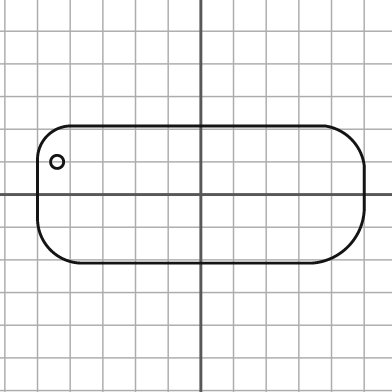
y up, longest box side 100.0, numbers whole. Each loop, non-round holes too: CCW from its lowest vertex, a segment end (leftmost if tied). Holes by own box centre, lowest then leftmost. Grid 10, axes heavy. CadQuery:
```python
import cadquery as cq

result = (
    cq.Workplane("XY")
    .moveTo(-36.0, -21.0)
    .lineTo(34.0, -21.0)
    .threePointArc((45.0, -16.0), (50.0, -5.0))
    .lineTo(50.0, 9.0)
    .threePointArc((46.0, 17.0), (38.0, 21.0))
    .lineTo(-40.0, 21.0)
    .threePointArc((-47.0, 18.0), (-50.0, 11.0))
    .lineTo(-50.0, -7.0)
    .threePointArc((-46.0, -17.0), (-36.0, -21.0))
    .close()
    .moveTo(-44.0, 10.0)
    .circle(2.0)
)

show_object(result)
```